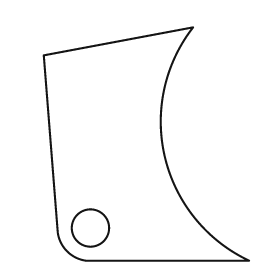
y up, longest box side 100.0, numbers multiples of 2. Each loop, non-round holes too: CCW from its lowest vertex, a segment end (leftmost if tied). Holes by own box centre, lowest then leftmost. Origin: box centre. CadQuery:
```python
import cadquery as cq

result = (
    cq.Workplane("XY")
    .moveTo(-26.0, -50.0)
    .lineTo(44.0, -50.0)
    .threePointArc((8.0, -6.0), (20.0, 50.0))
    .lineTo(-44.0, 38.0)
    .lineTo(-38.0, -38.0)
    .threePointArc((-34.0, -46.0), (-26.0, -50.0))
    .close()
    .moveTo(-24.0, -36.0)
    .circle(8.0)
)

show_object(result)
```